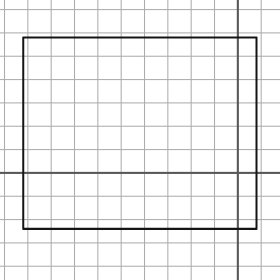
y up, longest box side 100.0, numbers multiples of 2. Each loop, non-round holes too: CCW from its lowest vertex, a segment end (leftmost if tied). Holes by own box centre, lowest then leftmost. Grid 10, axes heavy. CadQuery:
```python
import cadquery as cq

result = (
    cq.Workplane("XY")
    .moveTo(-92.0, -24.0)
    .lineTo(8.0, -24.0)
    .lineTo(8.0, 58.0)
    .lineTo(-92.0, 58.0)
    .close()
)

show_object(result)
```